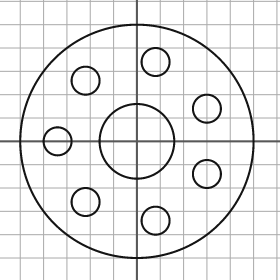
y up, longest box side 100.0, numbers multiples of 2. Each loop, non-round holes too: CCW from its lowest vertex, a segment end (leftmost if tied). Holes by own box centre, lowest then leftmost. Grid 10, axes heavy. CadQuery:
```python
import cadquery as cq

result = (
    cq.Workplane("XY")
    .moveTo(0.0, 0.0)
    .circle(50.0)
    .moveTo(8.0, -34.0)
    .circle(6.0)
    .moveTo(-22.0, -26.0)
    .circle(6.0)
    .moveTo(30.0, -14.0)
    .circle(6.0)
    .moveTo(-34.0, 0.0)
    .circle(6.0)
    .moveTo(0.0, 0.0)
    .circle(16.0)
    .moveTo(30.0, 14.0)
    .circle(6.0)
    .moveTo(-22.0, 26.0)
    .circle(6.0)
    .moveTo(8.0, 34.0)
    .circle(6.0)
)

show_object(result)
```